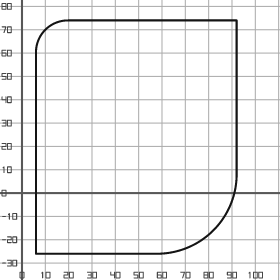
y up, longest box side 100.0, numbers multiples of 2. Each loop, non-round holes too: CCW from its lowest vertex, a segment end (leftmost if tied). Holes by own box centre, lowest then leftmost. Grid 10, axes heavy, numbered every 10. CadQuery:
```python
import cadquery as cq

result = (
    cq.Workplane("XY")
    .moveTo(6.0, -26.0)
    .lineTo(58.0, -26.0)
    .threePointArc((82.0, -16.0), (92.0, 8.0))
    .lineTo(92.0, 74.0)
    .lineTo(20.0, 74.0)
    .threePointArc((10.0, 70.0), (6.0, 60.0))
    .close()
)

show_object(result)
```